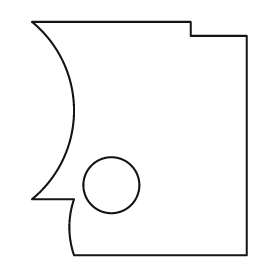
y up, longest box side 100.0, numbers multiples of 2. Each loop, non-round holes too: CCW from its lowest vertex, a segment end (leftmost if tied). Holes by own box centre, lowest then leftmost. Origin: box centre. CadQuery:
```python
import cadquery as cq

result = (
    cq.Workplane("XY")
    .moveTo(-28.0, -50.0)
    .lineTo(46.0, -50.0)
    .lineTo(46.0, 44.0)
    .lineTo(22.0, 44.0)
    .lineTo(22.0, 50.0)
    .lineTo(-46.0, 50.0)
    .threePointArc((-28.0, 12.0), (-46.0, -26.0))
    .lineTo(-28.0, -26.0)
    .threePointArc((-30.0, -38.0), (-28.0, -50.0))
    .close()
    .moveTo(-12.0, -20.0)
    .circle(12.0)
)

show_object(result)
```